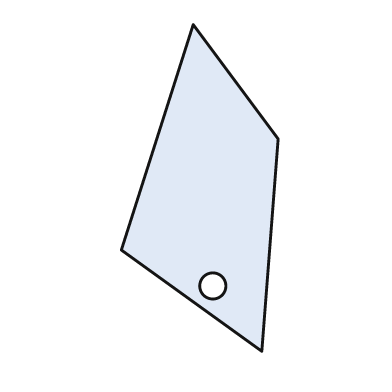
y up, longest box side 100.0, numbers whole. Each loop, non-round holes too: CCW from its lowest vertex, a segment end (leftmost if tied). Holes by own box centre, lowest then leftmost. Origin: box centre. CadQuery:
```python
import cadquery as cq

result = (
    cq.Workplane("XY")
    .moveTo(19.0, -50.0)
    .lineTo(24.0, 15.0)
    .lineTo(-2.0, 50.0)
    .lineTo(-24.0, -19.0)
    .close()
    .moveTo(4.0, -30.0)
    .circle(4.0)
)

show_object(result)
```